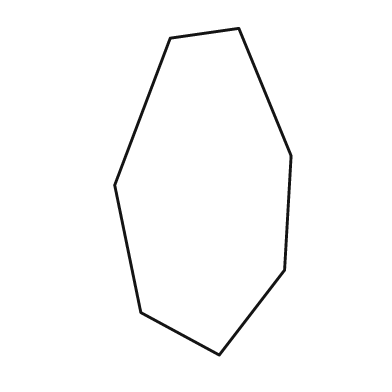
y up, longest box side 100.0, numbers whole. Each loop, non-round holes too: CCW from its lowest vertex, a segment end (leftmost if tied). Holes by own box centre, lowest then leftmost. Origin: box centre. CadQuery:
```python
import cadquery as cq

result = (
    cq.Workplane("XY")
    .moveTo(5.0, -50.0)
    .lineTo(25.0, -24.0)
    .lineTo(27.0, 11.0)
    .lineTo(11.0, 50.0)
    .lineTo(-10.0, 47.0)
    .lineTo(-27.0, 2.0)
    .lineTo(-19.0, -37.0)
    .close()
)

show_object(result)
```